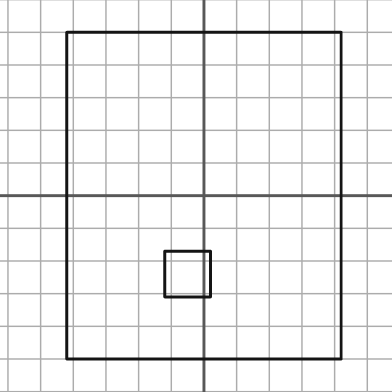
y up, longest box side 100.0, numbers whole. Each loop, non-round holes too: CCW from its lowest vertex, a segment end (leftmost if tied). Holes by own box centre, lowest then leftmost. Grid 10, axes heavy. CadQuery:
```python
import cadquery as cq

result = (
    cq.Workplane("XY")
    .moveTo(-42.0, -50.0)
    .lineTo(42.0, -50.0)
    .lineTo(42.0, 50.0)
    .lineTo(-42.0, 50.0)
    .close()
    .moveTo(-12.0, -31.0)
    .lineTo(2.0, -31.0)
    .lineTo(2.0, -17.0)
    .lineTo(-12.0, -17.0)
    .close()
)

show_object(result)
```